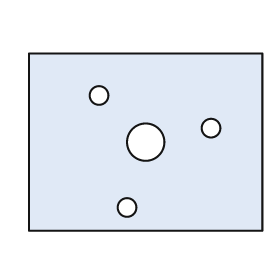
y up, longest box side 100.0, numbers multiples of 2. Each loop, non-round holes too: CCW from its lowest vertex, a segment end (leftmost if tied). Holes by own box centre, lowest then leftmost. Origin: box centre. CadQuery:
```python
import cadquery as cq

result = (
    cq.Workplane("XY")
    .moveTo(-50.0, -38.0)
    .lineTo(50.0, -38.0)
    .lineTo(50.0, 38.0)
    .lineTo(-50.0, 38.0)
    .close()
    .moveTo(-8.0, -28.0)
    .circle(4.0)
    .moveTo(0.0, 0.0)
    .circle(8.0)
    .moveTo(28.0, 6.0)
    .circle(4.0)
    .moveTo(-20.0, 20.0)
    .circle(4.0)
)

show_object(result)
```